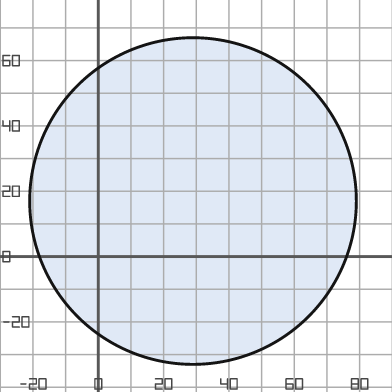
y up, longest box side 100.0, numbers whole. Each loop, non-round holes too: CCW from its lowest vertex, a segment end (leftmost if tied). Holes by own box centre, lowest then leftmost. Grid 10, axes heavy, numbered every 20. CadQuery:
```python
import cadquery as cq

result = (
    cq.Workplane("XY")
    .moveTo(29.0, 17.0)
    .circle(50.0)
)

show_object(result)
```